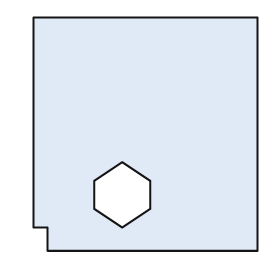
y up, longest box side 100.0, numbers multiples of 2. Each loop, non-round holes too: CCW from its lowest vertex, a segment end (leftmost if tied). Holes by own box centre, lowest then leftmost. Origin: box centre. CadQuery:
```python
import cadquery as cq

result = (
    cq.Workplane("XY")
    .moveTo(-42.0, -50.0)
    .lineTo(48.0, -50.0)
    .lineTo(48.0, 50.0)
    .lineTo(-48.0, 50.0)
    .lineTo(-48.0, -40.0)
    .lineTo(-42.0, -40.0)
    .close()
    .moveTo(-10.0, -40.0)
    .lineTo(2.0, -32.0)
    .lineTo(2.0, -20.0)
    .lineTo(-10.0, -12.0)
    .lineTo(-22.0, -20.0)
    .lineTo(-22.0, -32.0)
    .close()
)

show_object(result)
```